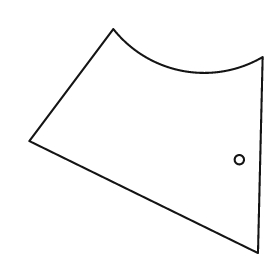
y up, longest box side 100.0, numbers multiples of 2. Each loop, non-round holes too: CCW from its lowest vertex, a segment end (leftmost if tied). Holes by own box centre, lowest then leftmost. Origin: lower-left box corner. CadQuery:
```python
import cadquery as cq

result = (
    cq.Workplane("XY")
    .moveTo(98.0, 0.0)
    .lineTo(100.0, 84.0)
    .threePointArc((66.0, 78.0), (36.0, 96.0))
    .lineTo(0.0, 48.0)
    .close()
    .moveTo(90.0, 40.0)
    .circle(2.0)
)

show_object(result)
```